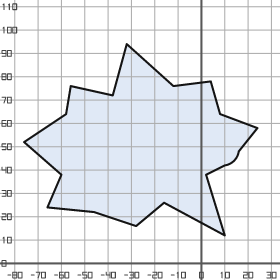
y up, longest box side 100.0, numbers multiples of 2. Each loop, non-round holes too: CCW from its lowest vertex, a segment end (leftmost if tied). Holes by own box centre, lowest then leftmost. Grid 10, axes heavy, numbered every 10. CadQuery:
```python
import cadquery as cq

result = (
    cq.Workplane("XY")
    .moveTo(10.0, 12.0)
    .lineTo(2.0, 38.0)
    .lineTo(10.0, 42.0)
    .threePointArc((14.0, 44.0), (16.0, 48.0))
    .lineTo(24.0, 58.0)
    .lineTo(8.0, 64.0)
    .lineTo(4.0, 78.0)
    .lineTo(-12.0, 76.0)
    .lineTo(-32.0, 94.0)
    .lineTo(-38.0, 72.0)
    .lineTo(-56.0, 76.0)
    .lineTo(-58.0, 64.0)
    .lineTo(-76.0, 52.0)
    .lineTo(-60.0, 38.0)
    .lineTo(-66.0, 24.0)
    .lineTo(-46.0, 22.0)
    .lineTo(-28.0, 16.0)
    .lineTo(-16.0, 26.0)
    .close()
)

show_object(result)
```